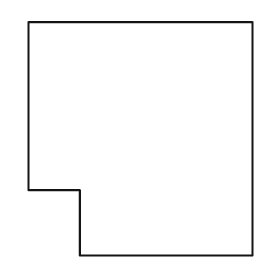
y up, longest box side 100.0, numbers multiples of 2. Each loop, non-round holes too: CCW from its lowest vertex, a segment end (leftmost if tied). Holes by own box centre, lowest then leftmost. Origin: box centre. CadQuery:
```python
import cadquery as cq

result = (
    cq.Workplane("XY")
    .moveTo(-26.0, -50.0)
    .lineTo(48.0, -50.0)
    .lineTo(48.0, 50.0)
    .lineTo(-48.0, 50.0)
    .lineTo(-48.0, -22.0)
    .lineTo(-26.0, -22.0)
    .close()
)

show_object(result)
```